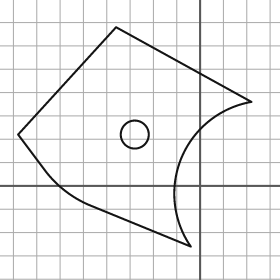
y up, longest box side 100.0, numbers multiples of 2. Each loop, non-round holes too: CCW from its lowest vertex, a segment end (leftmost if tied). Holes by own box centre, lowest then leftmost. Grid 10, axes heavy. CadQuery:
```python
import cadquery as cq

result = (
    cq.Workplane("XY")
    .moveTo(-4.0, -26.0)
    .threePointArc((-8.0, 12.0), (22.0, 36.0))
    .lineTo(-36.0, 68.0)
    .lineTo(-78.0, 22.0)
    .lineTo(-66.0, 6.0)
    .threePointArc((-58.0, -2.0), (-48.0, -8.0))
    .close()
    .moveTo(-28.0, 22.0)
    .circle(6.0)
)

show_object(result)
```